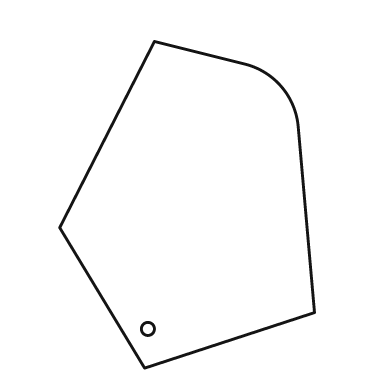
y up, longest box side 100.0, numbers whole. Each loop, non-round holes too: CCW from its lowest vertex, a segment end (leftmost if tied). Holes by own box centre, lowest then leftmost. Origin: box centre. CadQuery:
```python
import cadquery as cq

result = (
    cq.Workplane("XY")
    .moveTo(-13.0, -50.0)
    .lineTo(39.0, -33.0)
    .lineTo(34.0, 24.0)
    .threePointArc((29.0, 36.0), (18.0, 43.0))
    .lineTo(-10.0, 50.0)
    .lineTo(-39.0, -7.0)
    .close()
    .moveTo(-12.0, -38.0)
    .circle(2.0)
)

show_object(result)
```